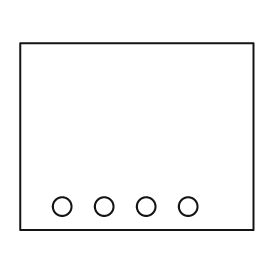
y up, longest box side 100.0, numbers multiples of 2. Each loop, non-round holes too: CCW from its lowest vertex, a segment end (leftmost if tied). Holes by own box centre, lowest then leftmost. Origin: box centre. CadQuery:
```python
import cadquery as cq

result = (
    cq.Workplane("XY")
    .moveTo(-50.0, -40.0)
    .lineTo(50.0, -40.0)
    .lineTo(50.0, 40.0)
    .lineTo(-50.0, 40.0)
    .close()
    .moveTo(-32.0, -30.0)
    .circle(4.0)
    .moveTo(-14.0, -30.0)
    .circle(4.0)
    .moveTo(4.0, -30.0)
    .circle(4.0)
    .moveTo(22.0, -30.0)
    .circle(4.0)
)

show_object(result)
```